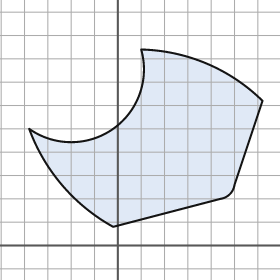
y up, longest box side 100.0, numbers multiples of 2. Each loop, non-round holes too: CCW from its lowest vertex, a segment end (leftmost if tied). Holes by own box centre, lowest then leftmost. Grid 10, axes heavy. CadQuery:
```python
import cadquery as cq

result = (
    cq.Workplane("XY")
    .moveTo(-2.0, 8.0)
    .lineTo(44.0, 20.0)
    .threePointArc((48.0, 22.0), (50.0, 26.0))
    .lineTo(62.0, 62.0)
    .threePointArc((38.0, 78.0), (10.0, 84.0))
    .threePointArc((-2.0, 50.0), (-38.0, 50.0))
    .threePointArc((-24.0, 26.0), (-2.0, 8.0))
    .close()
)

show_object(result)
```